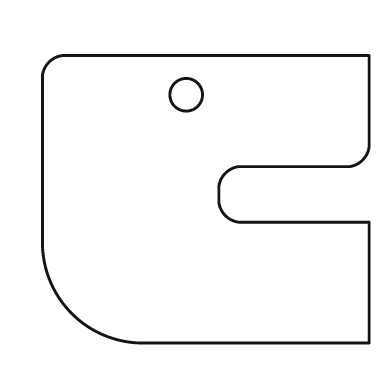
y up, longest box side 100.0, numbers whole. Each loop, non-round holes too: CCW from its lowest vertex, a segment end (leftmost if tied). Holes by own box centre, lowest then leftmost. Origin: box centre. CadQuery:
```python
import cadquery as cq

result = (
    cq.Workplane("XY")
    .moveTo(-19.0, -44.0)
    .lineTo(50.0, -44.0)
    .lineTo(50.0, -7.0)
    .lineTo(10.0, -7.0)
    .threePointArc((6.0, -5.0), (4.0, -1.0))
    .lineTo(4.0, 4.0)
    .threePointArc((6.0, 8.0), (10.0, 10.0))
    .lineTo(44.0, 10.0)
    .threePointArc((48.0, 12.0), (50.0, 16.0))
    .lineTo(50.0, 44.0)
    .lineTo(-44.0, 44.0)
    .threePointArc((-48.0, 42.0), (-50.0, 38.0))
    .lineTo(-50.0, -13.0)
    .threePointArc((-41.0, -35.0), (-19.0, -44.0))
    .close()
    .moveTo(-6.0, 32.0)
    .circle(5.0)
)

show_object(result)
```